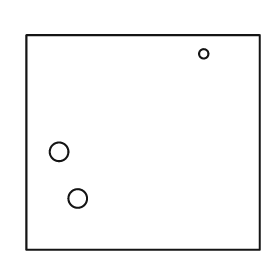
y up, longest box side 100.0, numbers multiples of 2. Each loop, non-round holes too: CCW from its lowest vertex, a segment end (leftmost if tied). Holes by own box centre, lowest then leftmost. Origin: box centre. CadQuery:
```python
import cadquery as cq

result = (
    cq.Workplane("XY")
    .moveTo(-50.0, -46.0)
    .lineTo(50.0, -46.0)
    .lineTo(50.0, 46.0)
    .lineTo(-50.0, 46.0)
    .close()
    .moveTo(-28.0, -24.0)
    .circle(4.0)
    .moveTo(-36.0, -4.0)
    .circle(4.0)
    .moveTo(26.0, 38.0)
    .circle(2.0)
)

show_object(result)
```